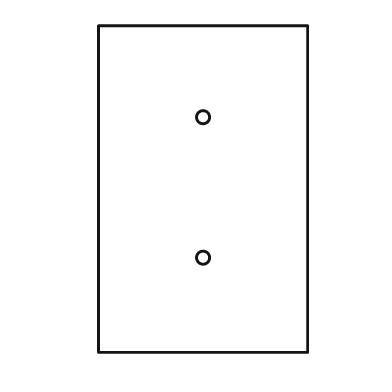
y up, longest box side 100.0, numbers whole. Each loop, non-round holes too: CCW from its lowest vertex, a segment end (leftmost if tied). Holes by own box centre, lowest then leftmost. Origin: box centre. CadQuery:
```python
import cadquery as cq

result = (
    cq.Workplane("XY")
    .moveTo(-32.0, -50.0)
    .lineTo(32.0, -50.0)
    .lineTo(32.0, 50.0)
    .lineTo(-32.0, 50.0)
    .close()
    .moveTo(0.0, -21.0)
    .circle(2.0)
    .moveTo(0.0, 22.0)
    .circle(2.0)
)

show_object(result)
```